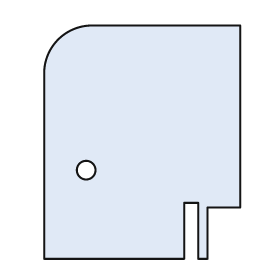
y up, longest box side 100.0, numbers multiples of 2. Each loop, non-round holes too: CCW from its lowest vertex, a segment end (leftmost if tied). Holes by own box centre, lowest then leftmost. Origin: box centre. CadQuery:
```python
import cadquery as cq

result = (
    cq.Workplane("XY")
    .moveTo(-42.0, -50.0)
    .lineTo(18.0, -50.0)
    .lineTo(18.0, -26.0)
    .lineTo(24.0, -26.0)
    .lineTo(24.0, -50.0)
    .lineTo(28.0, -50.0)
    .lineTo(28.0, -28.0)
    .lineTo(42.0, -28.0)
    .lineTo(42.0, 50.0)
    .lineTo(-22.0, 50.0)
    .threePointArc((-36.0, 44.0), (-42.0, 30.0))
    .close()
    .moveTo(-24.0, -12.0)
    .circle(4.0)
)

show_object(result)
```